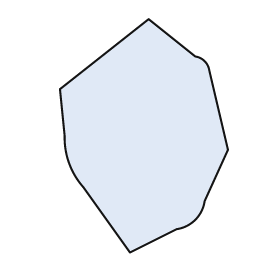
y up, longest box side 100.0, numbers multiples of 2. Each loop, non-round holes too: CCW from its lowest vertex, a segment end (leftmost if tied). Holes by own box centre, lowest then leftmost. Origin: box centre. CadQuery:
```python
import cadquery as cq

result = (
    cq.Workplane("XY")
    .moveTo(-6.0, -50.0)
    .lineTo(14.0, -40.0)
    .threePointArc((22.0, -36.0), (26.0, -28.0))
    .lineTo(36.0, -6.0)
    .lineTo(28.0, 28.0)
    .threePointArc((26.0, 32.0), (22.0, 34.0))
    .lineTo(2.0, 50.0)
    .lineTo(-36.0, 20.0)
    .lineTo(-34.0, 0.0)
    .threePointArc((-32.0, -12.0), (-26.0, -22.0))
    .close()
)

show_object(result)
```